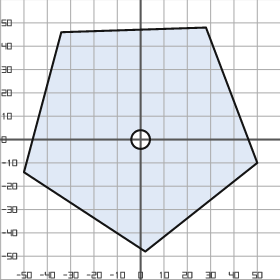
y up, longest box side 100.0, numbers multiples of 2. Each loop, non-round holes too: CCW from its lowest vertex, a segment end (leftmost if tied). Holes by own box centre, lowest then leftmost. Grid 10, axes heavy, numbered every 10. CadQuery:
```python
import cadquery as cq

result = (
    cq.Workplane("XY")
    .moveTo(2.0, -48.0)
    .lineTo(50.0, -10.0)
    .lineTo(28.0, 48.0)
    .lineTo(-34.0, 46.0)
    .lineTo(-50.0, -14.0)
    .close()
    .moveTo(0.0, 0.0)
    .circle(4.0)
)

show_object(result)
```